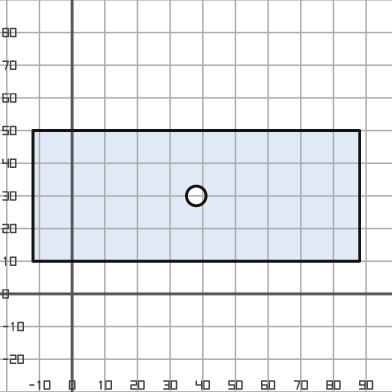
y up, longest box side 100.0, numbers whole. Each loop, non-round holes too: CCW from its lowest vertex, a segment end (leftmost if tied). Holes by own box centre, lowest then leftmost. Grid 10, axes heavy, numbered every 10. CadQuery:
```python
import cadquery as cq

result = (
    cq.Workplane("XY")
    .moveTo(-12.0, 10.0)
    .lineTo(88.0, 10.0)
    .lineTo(88.0, 50.0)
    .lineTo(-12.0, 50.0)
    .close()
    .moveTo(38.0, 30.0)
    .circle(3.0)
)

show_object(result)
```